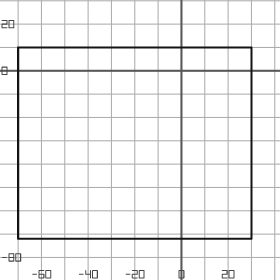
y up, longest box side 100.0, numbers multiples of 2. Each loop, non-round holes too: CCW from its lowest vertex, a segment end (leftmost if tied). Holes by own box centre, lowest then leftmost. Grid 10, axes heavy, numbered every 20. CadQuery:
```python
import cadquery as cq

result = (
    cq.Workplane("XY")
    .moveTo(-70.0, -72.0)
    .lineTo(30.0, -72.0)
    .lineTo(30.0, 10.0)
    .lineTo(-70.0, 10.0)
    .close()
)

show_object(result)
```